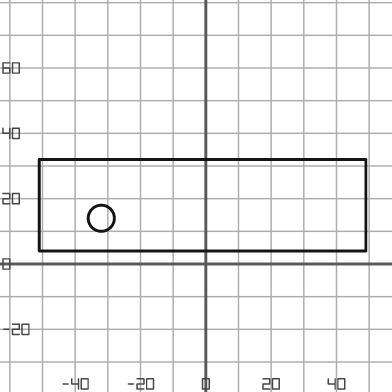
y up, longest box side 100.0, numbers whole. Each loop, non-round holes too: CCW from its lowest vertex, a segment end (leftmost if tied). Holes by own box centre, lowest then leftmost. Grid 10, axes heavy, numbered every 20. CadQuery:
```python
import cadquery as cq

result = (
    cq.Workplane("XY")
    .moveTo(-51.0, 4.0)
    .lineTo(49.0, 4.0)
    .lineTo(49.0, 32.0)
    .lineTo(-51.0, 32.0)
    .close()
    .moveTo(-32.0, 14.0)
    .circle(4.0)
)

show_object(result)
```